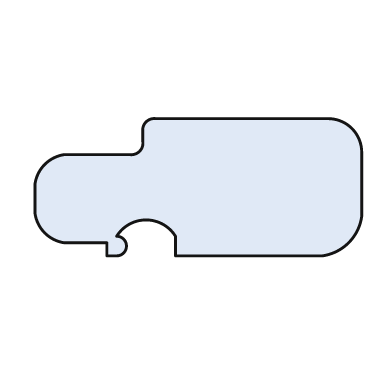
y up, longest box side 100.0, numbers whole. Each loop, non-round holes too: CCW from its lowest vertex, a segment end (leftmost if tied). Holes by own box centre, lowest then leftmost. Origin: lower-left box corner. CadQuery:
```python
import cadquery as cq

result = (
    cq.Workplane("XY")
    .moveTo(22.0, 0.0)
    .lineTo(25.0, 0.0)
    .threePointArc((28.0, 3.0), (25.0, 6.0))
    .threePointArc((34.0, 11.0), (43.0, 6.0))
    .lineTo(43.0, 0.0)
    .lineTo(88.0, 0.0)
    .threePointArc((96.0, 4.0), (100.0, 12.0))
    .lineTo(100.0, 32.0)
    .threePointArc((97.0, 39.0), (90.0, 42.0))
    .lineTo(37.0, 42.0)
    .threePointArc((34.0, 41.0), (33.0, 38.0))
    .lineTo(33.0, 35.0)
    .threePointArc((32.0, 32.0), (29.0, 31.0))
    .lineTo(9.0, 31.0)
    .threePointArc((3.0, 28.0), (0.0, 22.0))
    .lineTo(0.0, 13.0)
    .threePointArc((3.0, 7.0), (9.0, 4.0))
    .lineTo(22.0, 4.0)
    .close()
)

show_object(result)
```